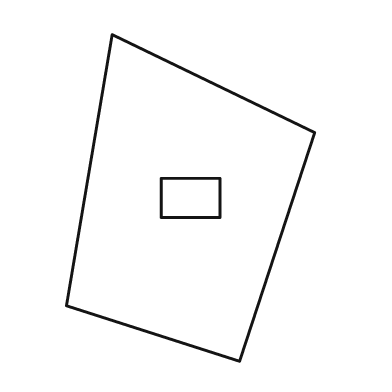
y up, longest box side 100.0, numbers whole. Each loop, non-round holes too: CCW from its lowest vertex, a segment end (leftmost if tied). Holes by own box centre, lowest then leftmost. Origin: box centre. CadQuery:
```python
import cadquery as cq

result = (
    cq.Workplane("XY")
    .moveTo(15.0, -50.0)
    .lineTo(38.0, 20.0)
    .lineTo(-24.0, 50.0)
    .lineTo(-38.0, -33.0)
    .close()
    .moveTo(-9.0, -6.0)
    .lineTo(9.0, -6.0)
    .lineTo(9.0, 6.0)
    .lineTo(-9.0, 6.0)
    .close()
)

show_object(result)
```